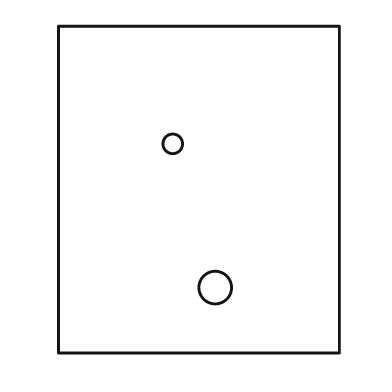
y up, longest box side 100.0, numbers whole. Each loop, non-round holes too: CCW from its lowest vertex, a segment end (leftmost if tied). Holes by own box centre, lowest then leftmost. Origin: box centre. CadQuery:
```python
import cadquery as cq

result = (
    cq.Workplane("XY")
    .moveTo(-43.0, -50.0)
    .lineTo(43.0, -50.0)
    .lineTo(43.0, 50.0)
    .lineTo(-43.0, 50.0)
    .close()
    .moveTo(5.0, -30.0)
    .circle(5.0)
    .moveTo(-8.0, 14.0)
    .circle(3.0)
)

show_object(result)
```